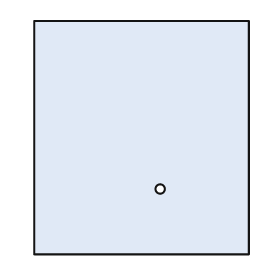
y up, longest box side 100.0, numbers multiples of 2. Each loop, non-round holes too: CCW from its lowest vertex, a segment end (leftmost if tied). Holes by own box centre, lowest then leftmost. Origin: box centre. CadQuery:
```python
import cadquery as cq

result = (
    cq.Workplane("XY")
    .moveTo(-46.0, -50.0)
    .lineTo(46.0, -50.0)
    .lineTo(46.0, 50.0)
    .lineTo(-46.0, 50.0)
    .close()
    .moveTo(8.0, -22.0)
    .circle(2.0)
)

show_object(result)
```